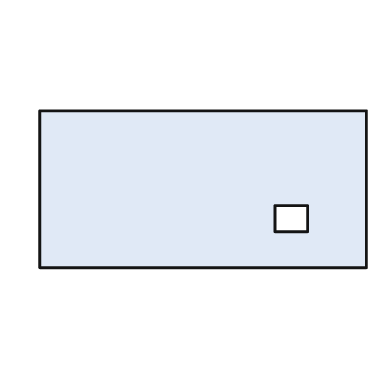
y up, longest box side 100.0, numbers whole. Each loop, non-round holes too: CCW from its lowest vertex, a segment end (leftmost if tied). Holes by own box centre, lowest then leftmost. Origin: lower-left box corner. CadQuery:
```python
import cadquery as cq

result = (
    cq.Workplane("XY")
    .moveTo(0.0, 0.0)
    .lineTo(100.0, 0.0)
    .lineTo(100.0, 48.0)
    .lineTo(0.0, 48.0)
    .close()
    .moveTo(72.0, 11.0)
    .lineTo(82.0, 11.0)
    .lineTo(82.0, 19.0)
    .lineTo(72.0, 19.0)
    .close()
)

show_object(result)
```